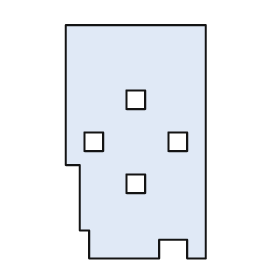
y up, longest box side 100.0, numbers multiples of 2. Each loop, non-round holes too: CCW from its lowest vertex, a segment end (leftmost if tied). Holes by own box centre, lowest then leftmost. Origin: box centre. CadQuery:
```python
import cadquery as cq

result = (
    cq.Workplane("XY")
    .moveTo(-20.0, -50.0)
    .lineTo(10.0, -50.0)
    .lineTo(10.0, -42.0)
    .lineTo(22.0, -42.0)
    .lineTo(22.0, -50.0)
    .lineTo(30.0, -50.0)
    .lineTo(30.0, 50.0)
    .lineTo(-30.0, 50.0)
    .lineTo(-30.0, -10.0)
    .lineTo(-24.0, -10.0)
    .lineTo(-24.0, -38.0)
    .lineTo(-20.0, -38.0)
    .close()
    .moveTo(-4.0, -22.0)
    .lineTo(4.0, -22.0)
    .lineTo(4.0, -14.0)
    .lineTo(-4.0, -14.0)
    .close()
    .moveTo(-22.0, -4.0)
    .lineTo(-14.0, -4.0)
    .lineTo(-14.0, 4.0)
    .lineTo(-22.0, 4.0)
    .close()
    .moveTo(14.0, -4.0)
    .lineTo(22.0, -4.0)
    .lineTo(22.0, 4.0)
    .lineTo(14.0, 4.0)
    .close()
    .moveTo(-4.0, 14.0)
    .lineTo(4.0, 14.0)
    .lineTo(4.0, 22.0)
    .lineTo(-4.0, 22.0)
    .close()
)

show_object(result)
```